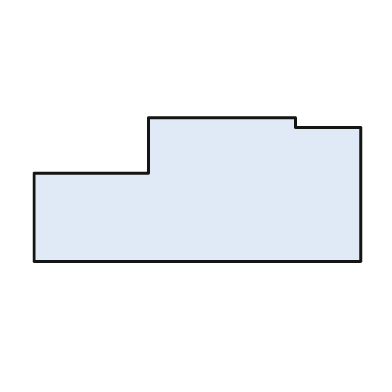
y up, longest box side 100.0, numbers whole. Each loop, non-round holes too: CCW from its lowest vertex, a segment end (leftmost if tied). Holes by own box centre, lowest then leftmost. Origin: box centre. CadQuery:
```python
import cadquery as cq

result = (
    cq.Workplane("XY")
    .moveTo(-50.0, -22.0)
    .lineTo(50.0, -22.0)
    .lineTo(50.0, 19.0)
    .lineTo(30.0, 19.0)
    .lineTo(30.0, 22.0)
    .lineTo(-15.0, 22.0)
    .lineTo(-15.0, 5.0)
    .lineTo(-50.0, 5.0)
    .close()
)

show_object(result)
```